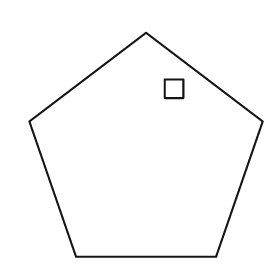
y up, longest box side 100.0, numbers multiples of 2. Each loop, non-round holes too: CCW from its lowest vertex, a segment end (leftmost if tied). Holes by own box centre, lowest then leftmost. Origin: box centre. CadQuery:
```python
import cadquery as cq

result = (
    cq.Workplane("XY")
    .moveTo(-30.0, -48.0)
    .lineTo(30.0, -48.0)
    .lineTo(50.0, 10.0)
    .lineTo(0.0, 48.0)
    .lineTo(-50.0, 10.0)
    .close()
    .moveTo(8.0, 20.0)
    .lineTo(16.0, 20.0)
    .lineTo(16.0, 28.0)
    .lineTo(8.0, 28.0)
    .close()
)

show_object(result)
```